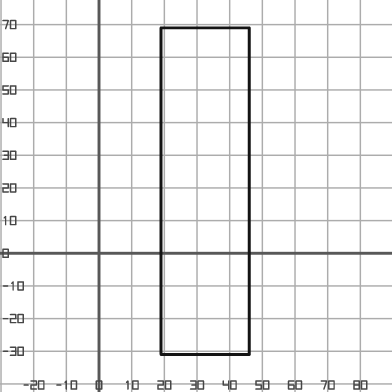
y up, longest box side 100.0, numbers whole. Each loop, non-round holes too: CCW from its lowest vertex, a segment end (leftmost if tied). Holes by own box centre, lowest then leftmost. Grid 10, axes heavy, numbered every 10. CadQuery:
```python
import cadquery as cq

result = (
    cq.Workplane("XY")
    .moveTo(19.0, -31.0)
    .lineTo(46.0, -31.0)
    .lineTo(46.0, 69.0)
    .lineTo(19.0, 69.0)
    .close()
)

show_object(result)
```